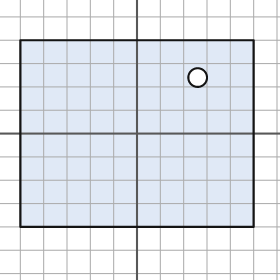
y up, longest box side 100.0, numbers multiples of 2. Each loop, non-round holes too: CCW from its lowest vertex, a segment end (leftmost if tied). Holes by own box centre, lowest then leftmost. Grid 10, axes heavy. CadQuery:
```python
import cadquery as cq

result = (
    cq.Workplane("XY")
    .moveTo(-50.0, -40.0)
    .lineTo(50.0, -40.0)
    .lineTo(50.0, 40.0)
    .lineTo(-50.0, 40.0)
    .close()
    .moveTo(26.0, 24.0)
    .circle(4.0)
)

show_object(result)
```